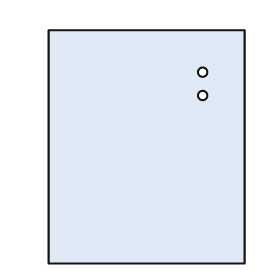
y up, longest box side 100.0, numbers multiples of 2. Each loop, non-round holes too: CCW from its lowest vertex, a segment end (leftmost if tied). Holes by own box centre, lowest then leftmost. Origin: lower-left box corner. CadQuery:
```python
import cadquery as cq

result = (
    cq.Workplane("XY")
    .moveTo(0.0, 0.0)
    .lineTo(84.0, 0.0)
    .lineTo(84.0, 100.0)
    .lineTo(0.0, 100.0)
    .close()
    .moveTo(66.0, 72.0)
    .circle(2.0)
    .moveTo(66.0, 82.0)
    .circle(2.0)
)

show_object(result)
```